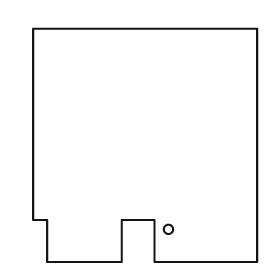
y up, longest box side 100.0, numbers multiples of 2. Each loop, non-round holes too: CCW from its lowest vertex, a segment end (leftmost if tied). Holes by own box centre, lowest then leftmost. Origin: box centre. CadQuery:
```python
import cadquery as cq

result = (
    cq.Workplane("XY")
    .moveTo(-42.0, -50.0)
    .lineTo(-10.0, -50.0)
    .lineTo(-10.0, -32.0)
    .lineTo(4.0, -32.0)
    .lineTo(4.0, -50.0)
    .lineTo(48.0, -50.0)
    .lineTo(48.0, 50.0)
    .lineTo(-48.0, 50.0)
    .lineTo(-48.0, -32.0)
    .lineTo(-42.0, -32.0)
    .close()
    .moveTo(10.0, -36.0)
    .circle(2.0)
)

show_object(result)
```